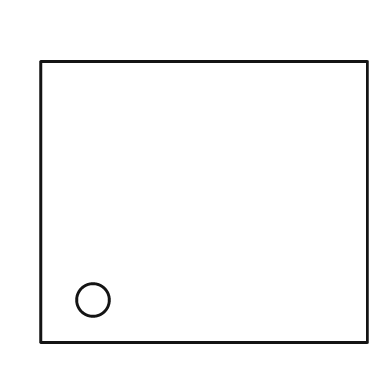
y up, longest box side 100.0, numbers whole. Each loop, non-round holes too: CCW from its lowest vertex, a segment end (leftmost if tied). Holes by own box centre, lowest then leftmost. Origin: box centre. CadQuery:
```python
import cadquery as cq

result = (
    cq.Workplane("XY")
    .moveTo(-50.0, -43.0)
    .lineTo(50.0, -43.0)
    .lineTo(50.0, 43.0)
    .lineTo(-50.0, 43.0)
    .close()
    .moveTo(-34.0, -30.0)
    .circle(5.0)
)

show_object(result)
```